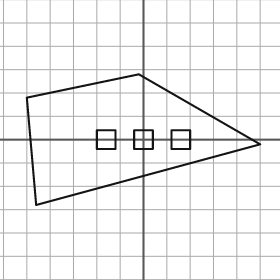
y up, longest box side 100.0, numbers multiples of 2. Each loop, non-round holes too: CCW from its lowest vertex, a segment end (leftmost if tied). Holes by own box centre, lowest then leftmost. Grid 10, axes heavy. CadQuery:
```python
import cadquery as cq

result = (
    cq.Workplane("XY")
    .moveTo(-46.0, -28.0)
    .lineTo(50.0, -2.0)
    .lineTo(-2.0, 28.0)
    .lineTo(-50.0, 18.0)
    .close()
    .moveTo(-20.0, -4.0)
    .lineTo(-12.0, -4.0)
    .lineTo(-12.0, 4.0)
    .lineTo(-20.0, 4.0)
    .close()
    .moveTo(-4.0, -4.0)
    .lineTo(4.0, -4.0)
    .lineTo(4.0, 4.0)
    .lineTo(-4.0, 4.0)
    .close()
    .moveTo(12.0, -4.0)
    .lineTo(20.0, -4.0)
    .lineTo(20.0, 4.0)
    .lineTo(12.0, 4.0)
    .close()
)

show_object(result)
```